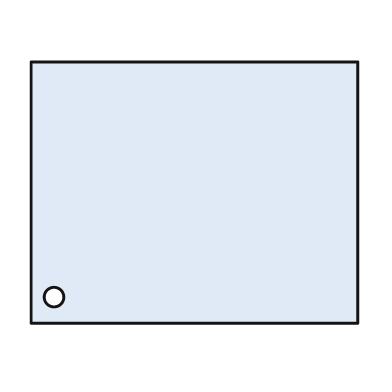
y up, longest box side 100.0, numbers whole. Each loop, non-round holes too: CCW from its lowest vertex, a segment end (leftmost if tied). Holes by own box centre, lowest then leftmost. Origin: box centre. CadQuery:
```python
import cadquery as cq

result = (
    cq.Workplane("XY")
    .moveTo(-50.0, -40.0)
    .lineTo(50.0, -40.0)
    .lineTo(50.0, 40.0)
    .lineTo(-50.0, 40.0)
    .close()
    .moveTo(-43.0, -32.0)
    .circle(3.0)
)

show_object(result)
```